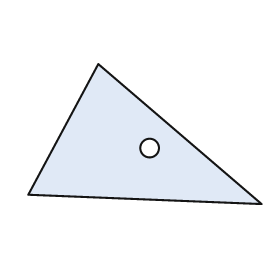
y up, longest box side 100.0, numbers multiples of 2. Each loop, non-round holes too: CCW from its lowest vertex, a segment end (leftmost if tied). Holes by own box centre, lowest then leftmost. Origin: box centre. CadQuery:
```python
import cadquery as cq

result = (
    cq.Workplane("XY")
    .moveTo(50.0, -30.0)
    .lineTo(-20.0, 30.0)
    .lineTo(-50.0, -26.0)
    .close()
    .moveTo(2.0, -6.0)
    .circle(4.0)
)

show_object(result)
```